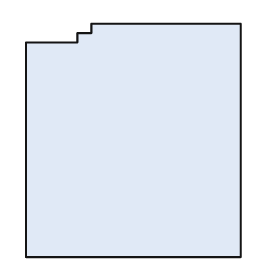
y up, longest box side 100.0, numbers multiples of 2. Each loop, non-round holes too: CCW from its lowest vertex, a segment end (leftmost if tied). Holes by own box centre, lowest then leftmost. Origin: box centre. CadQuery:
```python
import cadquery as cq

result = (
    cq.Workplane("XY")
    .moveTo(-46.0, -50.0)
    .lineTo(46.0, -50.0)
    .lineTo(46.0, 50.0)
    .lineTo(-18.0, 50.0)
    .lineTo(-18.0, 46.0)
    .lineTo(-24.0, 46.0)
    .lineTo(-24.0, 42.0)
    .lineTo(-46.0, 42.0)
    .close()
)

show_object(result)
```